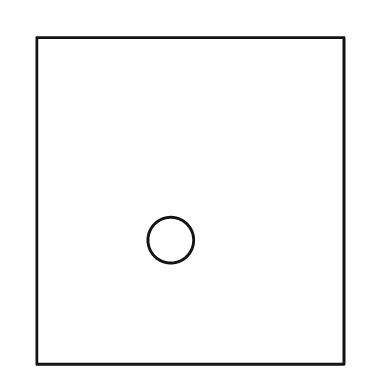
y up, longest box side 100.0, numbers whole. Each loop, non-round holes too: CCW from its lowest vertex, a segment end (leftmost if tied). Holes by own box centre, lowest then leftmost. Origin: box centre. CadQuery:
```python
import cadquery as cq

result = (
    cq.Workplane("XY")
    .moveTo(-47.0, -50.0)
    .lineTo(47.0, -50.0)
    .lineTo(47.0, 50.0)
    .lineTo(-47.0, 50.0)
    .close()
    .moveTo(-6.0, -12.0)
    .circle(7.0)
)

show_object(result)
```